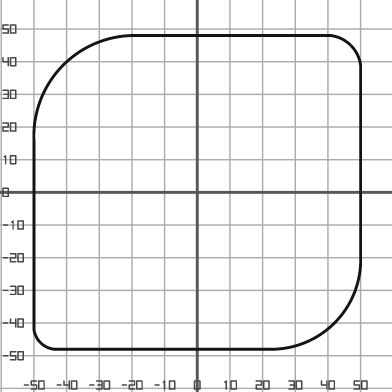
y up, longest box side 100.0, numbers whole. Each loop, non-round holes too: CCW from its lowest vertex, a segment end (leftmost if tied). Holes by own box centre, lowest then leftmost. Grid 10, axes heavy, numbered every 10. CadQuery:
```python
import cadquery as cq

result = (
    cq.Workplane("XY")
    .moveTo(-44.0, -48.0)
    .lineTo(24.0, -48.0)
    .threePointArc((42.0, -40.0), (50.0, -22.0))
    .lineTo(50.0, 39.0)
    .threePointArc((47.0, 45.0), (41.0, 48.0))
    .lineTo(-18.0, 48.0)
    .threePointArc((-41.0, 39.0), (-50.0, 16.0))
    .lineTo(-50.0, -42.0)
    .threePointArc((-48.0, -46.0), (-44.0, -48.0))
    .close()
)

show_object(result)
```